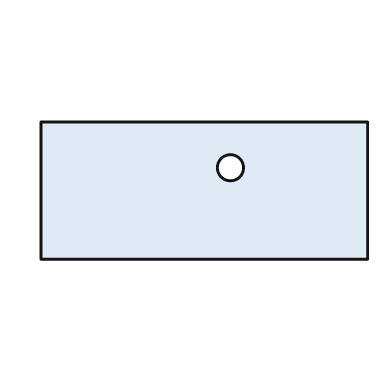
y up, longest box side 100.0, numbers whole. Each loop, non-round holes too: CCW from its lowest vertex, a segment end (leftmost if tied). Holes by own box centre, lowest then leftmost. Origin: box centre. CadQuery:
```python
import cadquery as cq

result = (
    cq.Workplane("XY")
    .moveTo(-50.0, -21.0)
    .lineTo(50.0, -21.0)
    .lineTo(50.0, 21.0)
    .lineTo(-50.0, 21.0)
    .close()
    .moveTo(8.0, 7.0)
    .circle(4.0)
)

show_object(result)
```